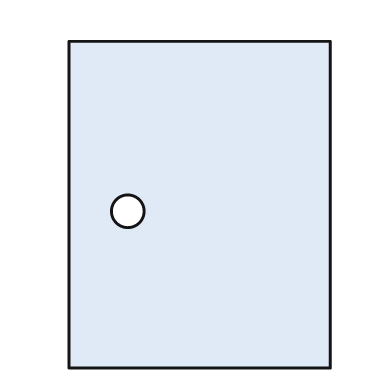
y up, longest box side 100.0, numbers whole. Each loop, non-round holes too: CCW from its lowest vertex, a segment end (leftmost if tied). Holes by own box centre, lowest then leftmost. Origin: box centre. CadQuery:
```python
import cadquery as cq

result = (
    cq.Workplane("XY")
    .moveTo(-40.0, -50.0)
    .lineTo(40.0, -50.0)
    .lineTo(40.0, 50.0)
    .lineTo(-40.0, 50.0)
    .close()
    .moveTo(-22.0, -2.0)
    .circle(5.0)
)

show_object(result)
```